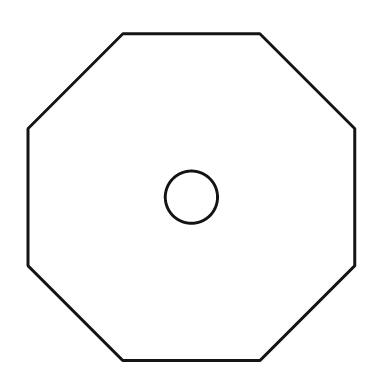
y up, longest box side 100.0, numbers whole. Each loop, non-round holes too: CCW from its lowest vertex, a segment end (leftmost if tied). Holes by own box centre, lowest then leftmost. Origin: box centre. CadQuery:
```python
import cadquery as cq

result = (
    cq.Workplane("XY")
    .moveTo(-21.0, -50.0)
    .lineTo(21.0, -50.0)
    .lineTo(50.0, -21.0)
    .lineTo(50.0, 21.0)
    .lineTo(21.0, 50.0)
    .lineTo(-21.0, 50.0)
    .lineTo(-50.0, 21.0)
    .lineTo(-50.0, -21.0)
    .close()
    .moveTo(0.0, 0.0)
    .circle(8.0)
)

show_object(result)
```